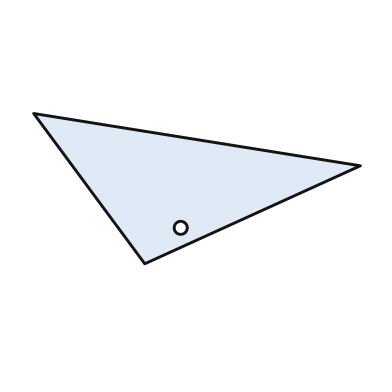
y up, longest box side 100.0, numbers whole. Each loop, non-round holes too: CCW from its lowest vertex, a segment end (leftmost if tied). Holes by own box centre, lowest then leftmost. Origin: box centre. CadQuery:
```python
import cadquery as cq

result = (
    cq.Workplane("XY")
    .moveTo(-16.0, -23.0)
    .lineTo(50.0, 7.0)
    .lineTo(-50.0, 23.0)
    .close()
    .moveTo(-5.0, -12.0)
    .circle(2.0)
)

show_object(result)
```